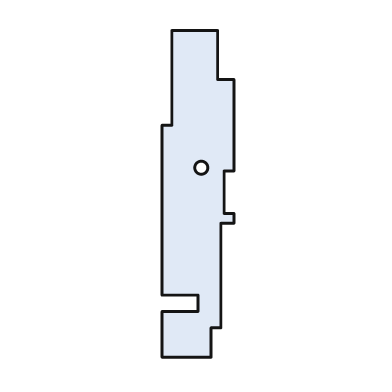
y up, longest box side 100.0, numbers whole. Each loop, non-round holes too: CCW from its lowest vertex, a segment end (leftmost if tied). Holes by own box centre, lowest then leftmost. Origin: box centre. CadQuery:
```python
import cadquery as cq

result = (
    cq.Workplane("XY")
    .moveTo(-11.0, -50.0)
    .lineTo(4.0, -50.0)
    .lineTo(4.0, -41.0)
    .lineTo(7.0, -41.0)
    .lineTo(7.0, -9.0)
    .lineTo(11.0, -9.0)
    .lineTo(11.0, -6.0)
    .lineTo(8.0, -6.0)
    .lineTo(8.0, 7.0)
    .lineTo(11.0, 7.0)
    .lineTo(11.0, 35.0)
    .lineTo(6.0, 35.0)
    .lineTo(6.0, 50.0)
    .lineTo(-8.0, 50.0)
    .lineTo(-8.0, 21.0)
    .lineTo(-11.0, 21.0)
    .lineTo(-11.0, -31.0)
    .lineTo(0.0, -31.0)
    .lineTo(0.0, -36.0)
    .lineTo(-11.0, -36.0)
    .close()
    .moveTo(1.0, 8.0)
    .circle(2.0)
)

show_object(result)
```